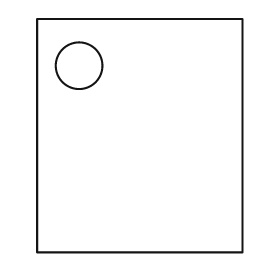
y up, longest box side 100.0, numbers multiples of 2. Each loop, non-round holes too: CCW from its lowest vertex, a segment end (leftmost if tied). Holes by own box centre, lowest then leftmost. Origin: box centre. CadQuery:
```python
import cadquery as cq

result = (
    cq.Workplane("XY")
    .moveTo(-44.0, -50.0)
    .lineTo(44.0, -50.0)
    .lineTo(44.0, 50.0)
    .lineTo(-44.0, 50.0)
    .close()
    .moveTo(-26.0, 30.0)
    .circle(10.0)
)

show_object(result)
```